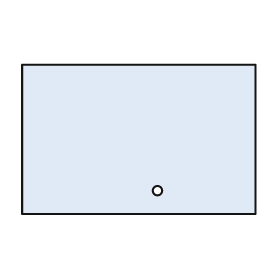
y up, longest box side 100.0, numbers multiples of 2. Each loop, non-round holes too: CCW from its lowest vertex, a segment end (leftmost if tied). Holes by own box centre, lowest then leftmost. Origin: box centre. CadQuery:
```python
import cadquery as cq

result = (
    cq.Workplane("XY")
    .moveTo(-50.0, -32.0)
    .lineTo(50.0, -32.0)
    .lineTo(50.0, 32.0)
    .lineTo(-50.0, 32.0)
    .close()
    .moveTo(8.0, -22.0)
    .circle(2.0)
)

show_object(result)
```